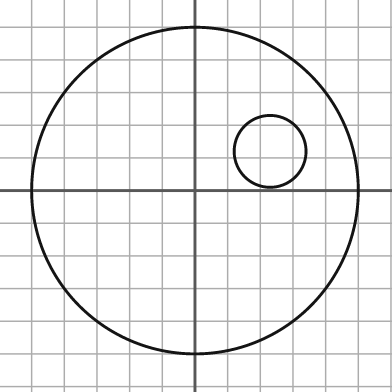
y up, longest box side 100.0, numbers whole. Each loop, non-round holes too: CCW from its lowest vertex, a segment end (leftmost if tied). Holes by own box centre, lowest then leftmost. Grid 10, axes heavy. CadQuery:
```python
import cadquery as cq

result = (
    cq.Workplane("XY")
    .moveTo(0.0, 0.0)
    .circle(50.0)
    .moveTo(23.0, 12.0)
    .circle(11.0)
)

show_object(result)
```